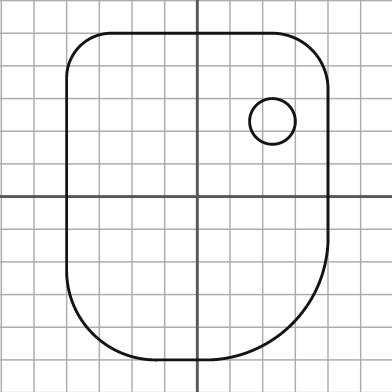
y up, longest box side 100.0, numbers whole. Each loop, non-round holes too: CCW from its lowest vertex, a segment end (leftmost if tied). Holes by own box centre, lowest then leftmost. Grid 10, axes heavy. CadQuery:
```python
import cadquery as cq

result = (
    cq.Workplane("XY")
    .moveTo(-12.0, -50.0)
    .lineTo(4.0, -50.0)
    .threePointArc((29.0, -39.0), (40.0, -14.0))
    .lineTo(40.0, 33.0)
    .threePointArc((35.0, 45.0), (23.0, 50.0))
    .lineTo(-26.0, 50.0)
    .threePointArc((-36.0, 46.0), (-40.0, 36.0))
    .lineTo(-40.0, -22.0)
    .threePointArc((-32.0, -42.0), (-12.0, -50.0))
    .close()
    .moveTo(23.0, 23.0)
    .circle(7.0)
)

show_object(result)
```